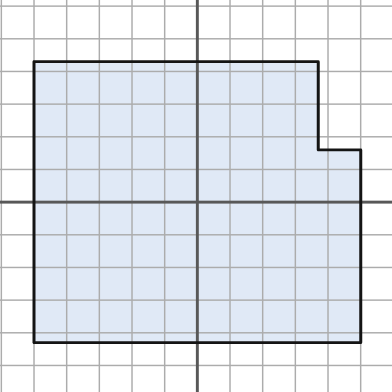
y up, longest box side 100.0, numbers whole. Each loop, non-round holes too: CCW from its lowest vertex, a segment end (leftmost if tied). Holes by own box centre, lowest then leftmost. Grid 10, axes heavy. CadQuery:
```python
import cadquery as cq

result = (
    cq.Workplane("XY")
    .moveTo(-50.0, -43.0)
    .lineTo(50.0, -43.0)
    .lineTo(50.0, 16.0)
    .lineTo(37.0, 16.0)
    .lineTo(37.0, 43.0)
    .lineTo(-50.0, 43.0)
    .close()
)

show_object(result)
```